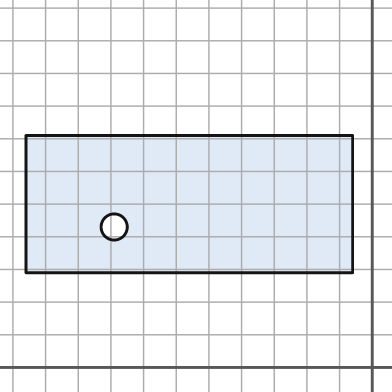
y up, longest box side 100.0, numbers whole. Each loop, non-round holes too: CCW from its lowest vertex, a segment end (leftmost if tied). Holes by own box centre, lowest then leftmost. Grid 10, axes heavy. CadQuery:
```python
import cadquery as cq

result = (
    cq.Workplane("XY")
    .moveTo(-106.0, 29.0)
    .lineTo(-6.0, 29.0)
    .lineTo(-6.0, 71.0)
    .lineTo(-106.0, 71.0)
    .close()
    .moveTo(-79.0, 43.0)
    .circle(4.0)
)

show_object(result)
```